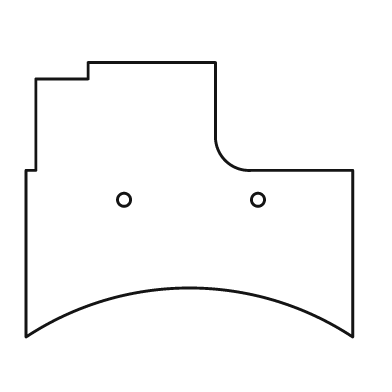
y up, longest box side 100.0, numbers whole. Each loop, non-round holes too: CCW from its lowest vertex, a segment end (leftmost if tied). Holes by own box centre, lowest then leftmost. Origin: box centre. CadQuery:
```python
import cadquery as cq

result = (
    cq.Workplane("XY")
    .moveTo(-50.0, -42.0)
    .threePointArc((0.0, -27.0), (50.0, -42.0))
    .lineTo(50.0, 9.0)
    .lineTo(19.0, 9.0)
    .threePointArc((11.0, 12.0), (8.0, 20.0))
    .lineTo(8.0, 42.0)
    .lineTo(-31.0, 42.0)
    .lineTo(-31.0, 37.0)
    .lineTo(-47.0, 37.0)
    .lineTo(-47.0, 9.0)
    .lineTo(-50.0, 9.0)
    .close()
    .moveTo(-20.0, 0.0)
    .circle(2.0)
    .moveTo(21.0, 0.0)
    .circle(2.0)
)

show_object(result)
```